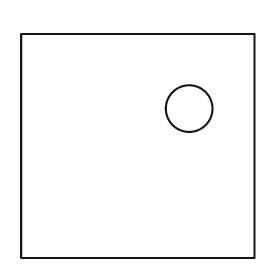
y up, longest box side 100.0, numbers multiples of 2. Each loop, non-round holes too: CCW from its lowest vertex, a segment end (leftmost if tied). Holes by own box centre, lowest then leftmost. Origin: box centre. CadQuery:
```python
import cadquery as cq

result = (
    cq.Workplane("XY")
    .moveTo(-50.0, -48.0)
    .lineTo(50.0, -48.0)
    .lineTo(50.0, 48.0)
    .lineTo(-50.0, 48.0)
    .close()
    .moveTo(22.0, 16.0)
    .circle(10.0)
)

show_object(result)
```